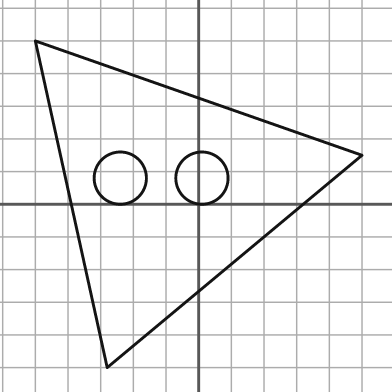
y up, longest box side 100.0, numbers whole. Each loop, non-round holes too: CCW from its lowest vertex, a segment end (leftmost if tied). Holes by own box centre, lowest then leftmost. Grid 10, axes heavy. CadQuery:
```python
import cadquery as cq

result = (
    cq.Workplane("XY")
    .moveTo(-28.0, -50.0)
    .lineTo(50.0, 15.0)
    .lineTo(-50.0, 50.0)
    .close()
    .moveTo(-24.0, 8.0)
    .circle(8.0)
    .moveTo(1.0, 8.0)
    .circle(8.0)
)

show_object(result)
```